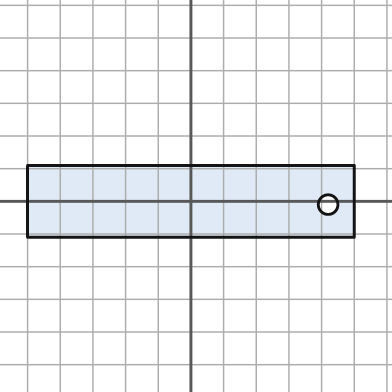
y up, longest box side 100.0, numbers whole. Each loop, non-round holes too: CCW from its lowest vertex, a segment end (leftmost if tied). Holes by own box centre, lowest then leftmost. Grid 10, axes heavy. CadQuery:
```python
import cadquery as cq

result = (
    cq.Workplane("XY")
    .moveTo(-50.0, -11.0)
    .lineTo(50.0, -11.0)
    .lineTo(50.0, 11.0)
    .lineTo(-50.0, 11.0)
    .close()
    .moveTo(42.0, -1.0)
    .circle(3.0)
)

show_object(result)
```